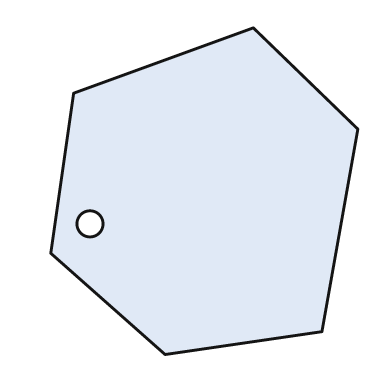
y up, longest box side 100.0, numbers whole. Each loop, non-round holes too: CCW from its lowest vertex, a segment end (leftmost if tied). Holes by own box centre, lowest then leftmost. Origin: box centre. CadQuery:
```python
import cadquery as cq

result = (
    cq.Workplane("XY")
    .moveTo(-12.0, -50.0)
    .lineTo(36.0, -43.0)
    .lineTo(47.0, 19.0)
    .lineTo(15.0, 50.0)
    .lineTo(-40.0, 30.0)
    .lineTo(-47.0, -19.0)
    .close()
    .moveTo(-35.0, -10.0)
    .circle(4.0)
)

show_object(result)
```